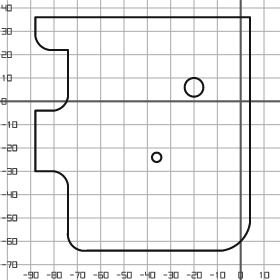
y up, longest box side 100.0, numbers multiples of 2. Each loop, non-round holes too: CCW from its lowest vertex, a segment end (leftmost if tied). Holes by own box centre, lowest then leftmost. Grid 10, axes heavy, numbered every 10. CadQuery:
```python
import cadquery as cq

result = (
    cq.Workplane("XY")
    .moveTo(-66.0, -64.0)
    .lineTo(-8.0, -64.0)
    .threePointArc((0.0, -60.0), (4.0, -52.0))
    .lineTo(4.0, 36.0)
    .lineTo(-88.0, 36.0)
    .lineTo(-88.0, 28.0)
    .threePointArc((-86.0, 24.0), (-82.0, 22.0))
    .lineTo(-74.0, 22.0)
    .lineTo(-74.0, 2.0)
    .threePointArc((-76.0, -2.0), (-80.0, -4.0))
    .lineTo(-88.0, -4.0)
    .lineTo(-88.0, -30.0)
    .lineTo(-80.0, -30.0)
    .threePointArc((-76.0, -32.0), (-74.0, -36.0))
    .lineTo(-74.0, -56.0)
    .threePointArc((-72.0, -62.0), (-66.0, -64.0))
    .close()
    .moveTo(-36.0, -24.0)
    .circle(2.0)
    .moveTo(-20.0, 6.0)
    .circle(4.0)
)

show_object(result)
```